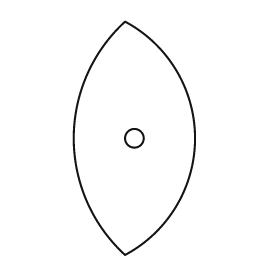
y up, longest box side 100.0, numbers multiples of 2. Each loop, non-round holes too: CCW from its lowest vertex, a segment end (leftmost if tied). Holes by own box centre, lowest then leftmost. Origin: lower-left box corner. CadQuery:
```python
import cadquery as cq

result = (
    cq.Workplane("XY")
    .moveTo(22.0, 0.0)
    .threePointArc((52.0, 50.0), (22.0, 100.0))
    .threePointArc((0.0, 50.0), (22.0, 0.0))
    .close()
    .moveTo(26.0, 50.0)
    .circle(4.0)
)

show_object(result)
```